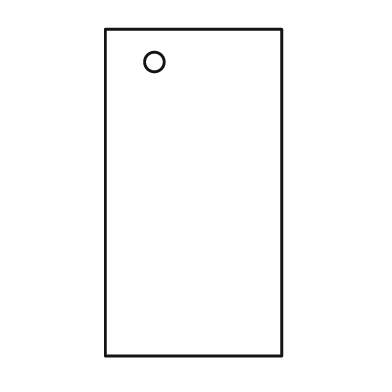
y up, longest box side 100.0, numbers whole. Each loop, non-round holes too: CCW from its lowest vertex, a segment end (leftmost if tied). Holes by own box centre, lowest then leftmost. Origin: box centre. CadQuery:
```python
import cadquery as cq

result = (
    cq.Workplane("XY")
    .moveTo(-27.0, -50.0)
    .lineTo(27.0, -50.0)
    .lineTo(27.0, 50.0)
    .lineTo(-27.0, 50.0)
    .close()
    .moveTo(-12.0, 40.0)
    .circle(3.0)
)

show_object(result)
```